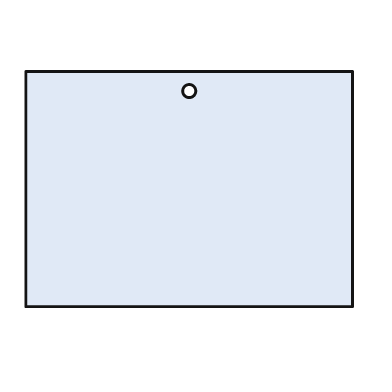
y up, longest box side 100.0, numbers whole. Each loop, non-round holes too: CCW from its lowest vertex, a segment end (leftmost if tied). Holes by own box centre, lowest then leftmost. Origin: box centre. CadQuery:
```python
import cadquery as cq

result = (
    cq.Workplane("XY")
    .moveTo(-50.0, -36.0)
    .lineTo(50.0, -36.0)
    .lineTo(50.0, 36.0)
    .lineTo(-50.0, 36.0)
    .close()
    .moveTo(0.0, 30.0)
    .circle(2.0)
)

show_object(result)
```